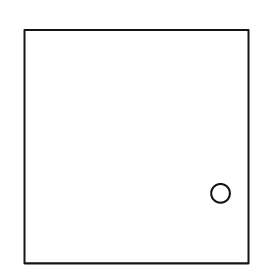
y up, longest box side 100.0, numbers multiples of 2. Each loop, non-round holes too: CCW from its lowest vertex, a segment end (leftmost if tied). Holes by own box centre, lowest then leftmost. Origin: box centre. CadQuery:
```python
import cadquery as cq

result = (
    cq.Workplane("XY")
    .moveTo(-48.0, -50.0)
    .lineTo(48.0, -50.0)
    .lineTo(48.0, 50.0)
    .lineTo(-48.0, 50.0)
    .close()
    .moveTo(36.0, -20.0)
    .circle(4.0)
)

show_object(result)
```